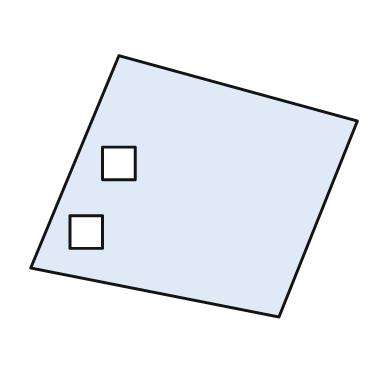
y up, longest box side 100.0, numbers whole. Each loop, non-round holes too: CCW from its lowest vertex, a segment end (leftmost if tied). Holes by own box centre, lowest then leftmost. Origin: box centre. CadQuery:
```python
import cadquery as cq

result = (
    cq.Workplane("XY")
    .moveTo(26.0, -40.0)
    .lineTo(50.0, 20.0)
    .lineTo(-23.0, 40.0)
    .lineTo(-50.0, -25.0)
    .close()
    .moveTo(-38.0, -19.0)
    .lineTo(-28.0, -19.0)
    .lineTo(-28.0, -9.0)
    .lineTo(-38.0, -9.0)
    .close()
    .moveTo(-28.0, 2.0)
    .lineTo(-18.0, 2.0)
    .lineTo(-18.0, 12.0)
    .lineTo(-28.0, 12.0)
    .close()
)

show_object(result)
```